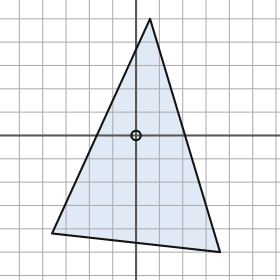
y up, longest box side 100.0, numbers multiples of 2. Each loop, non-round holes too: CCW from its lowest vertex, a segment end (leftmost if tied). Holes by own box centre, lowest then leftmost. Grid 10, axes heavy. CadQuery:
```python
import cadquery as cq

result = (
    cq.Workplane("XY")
    .moveTo(36.0, -50.0)
    .lineTo(6.0, 50.0)
    .lineTo(-36.0, -42.0)
    .close()
    .moveTo(0.0, 0.0)
    .circle(2.0)
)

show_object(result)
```